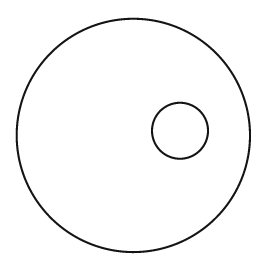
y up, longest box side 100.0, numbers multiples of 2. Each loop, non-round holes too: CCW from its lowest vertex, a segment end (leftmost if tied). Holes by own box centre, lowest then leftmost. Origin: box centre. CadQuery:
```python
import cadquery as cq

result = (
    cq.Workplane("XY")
    .moveTo(0.0, 0.0)
    .circle(50.0)
    .moveTo(20.0, 2.0)
    .circle(12.0)
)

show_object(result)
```